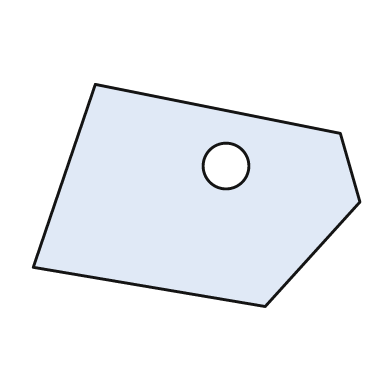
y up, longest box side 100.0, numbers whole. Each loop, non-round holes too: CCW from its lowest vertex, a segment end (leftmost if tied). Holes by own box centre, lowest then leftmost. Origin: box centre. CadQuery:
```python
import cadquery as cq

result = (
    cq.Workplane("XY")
    .moveTo(21.0, -34.0)
    .lineTo(50.0, -2.0)
    .lineTo(44.0, 19.0)
    .lineTo(-31.0, 34.0)
    .lineTo(-50.0, -22.0)
    .close()
    .moveTo(9.0, 9.0)
    .circle(7.0)
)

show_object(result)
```